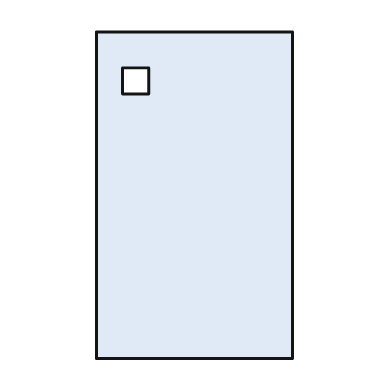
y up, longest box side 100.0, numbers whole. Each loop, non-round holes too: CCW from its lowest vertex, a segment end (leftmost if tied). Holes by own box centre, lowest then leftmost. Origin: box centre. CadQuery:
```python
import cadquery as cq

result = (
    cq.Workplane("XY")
    .moveTo(-30.0, -50.0)
    .lineTo(30.0, -50.0)
    .lineTo(30.0, 50.0)
    .lineTo(-30.0, 50.0)
    .close()
    .moveTo(-22.0, 31.0)
    .lineTo(-14.0, 31.0)
    .lineTo(-14.0, 39.0)
    .lineTo(-22.0, 39.0)
    .close()
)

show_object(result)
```